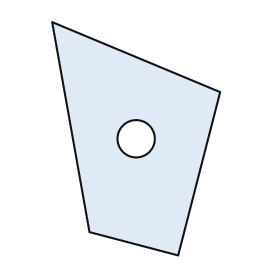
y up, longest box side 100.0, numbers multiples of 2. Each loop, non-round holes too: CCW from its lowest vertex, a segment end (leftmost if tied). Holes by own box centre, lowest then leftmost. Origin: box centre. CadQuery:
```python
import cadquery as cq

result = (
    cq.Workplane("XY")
    .moveTo(18.0, -50.0)
    .lineTo(36.0, 20.0)
    .lineTo(-36.0, 50.0)
    .lineTo(-20.0, -40.0)
    .close()
    .moveTo(0.0, 0.0)
    .circle(8.0)
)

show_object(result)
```